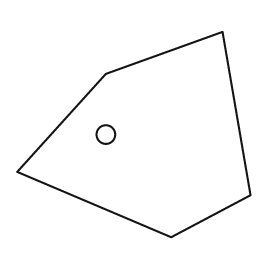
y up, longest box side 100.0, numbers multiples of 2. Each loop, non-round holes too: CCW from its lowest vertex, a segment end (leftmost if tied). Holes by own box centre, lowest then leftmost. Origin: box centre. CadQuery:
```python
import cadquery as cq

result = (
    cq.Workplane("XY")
    .moveTo(16.0, -44.0)
    .lineTo(50.0, -26.0)
    .lineTo(38.0, 44.0)
    .lineTo(-12.0, 26.0)
    .lineTo(-50.0, -16.0)
    .close()
    .moveTo(-12.0, 0.0)
    .circle(4.0)
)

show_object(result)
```